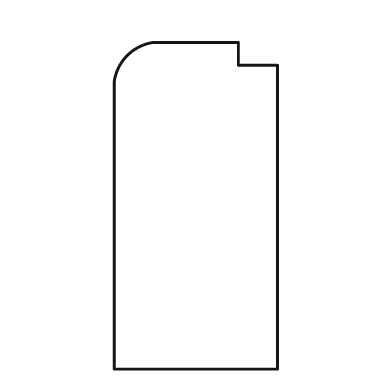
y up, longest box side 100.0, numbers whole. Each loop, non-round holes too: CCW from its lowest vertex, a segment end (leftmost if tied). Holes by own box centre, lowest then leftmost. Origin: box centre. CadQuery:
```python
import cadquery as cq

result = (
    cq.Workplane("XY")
    .moveTo(-25.0, -50.0)
    .lineTo(25.0, -50.0)
    .lineTo(25.0, 43.0)
    .lineTo(13.0, 43.0)
    .lineTo(13.0, 50.0)
    .lineTo(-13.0, 50.0)
    .threePointArc((-21.0, 46.0), (-25.0, 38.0))
    .close()
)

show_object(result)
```